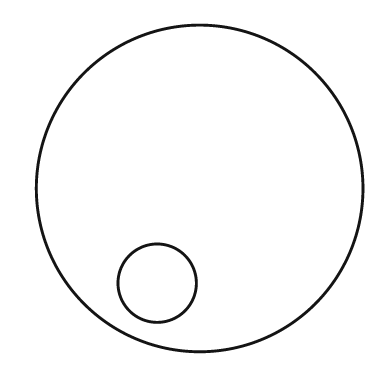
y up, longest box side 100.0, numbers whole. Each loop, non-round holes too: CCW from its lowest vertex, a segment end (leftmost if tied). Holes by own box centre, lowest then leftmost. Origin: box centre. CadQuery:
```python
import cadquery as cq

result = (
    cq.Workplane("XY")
    .moveTo(0.0, 0.0)
    .circle(50.0)
    .moveTo(-13.0, -29.0)
    .circle(12.0)
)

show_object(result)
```